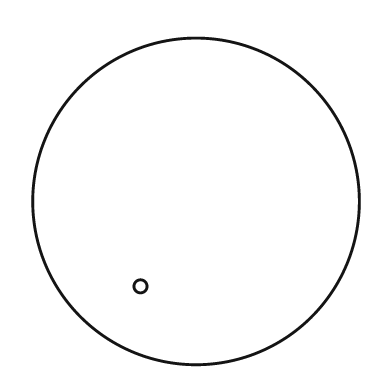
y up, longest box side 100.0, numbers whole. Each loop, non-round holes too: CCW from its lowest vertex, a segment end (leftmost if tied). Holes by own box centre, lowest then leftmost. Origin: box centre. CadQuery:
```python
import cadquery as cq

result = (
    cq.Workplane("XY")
    .moveTo(0.0, 0.0)
    .circle(50.0)
    .moveTo(-17.0, -26.0)
    .circle(2.0)
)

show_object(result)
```